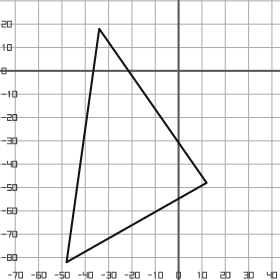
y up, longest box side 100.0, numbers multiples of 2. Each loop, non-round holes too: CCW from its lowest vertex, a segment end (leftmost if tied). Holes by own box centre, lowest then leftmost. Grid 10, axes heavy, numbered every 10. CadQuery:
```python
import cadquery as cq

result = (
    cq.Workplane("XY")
    .moveTo(-48.0, -82.0)
    .lineTo(12.0, -48.0)
    .lineTo(-34.0, 18.0)
    .close()
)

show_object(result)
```